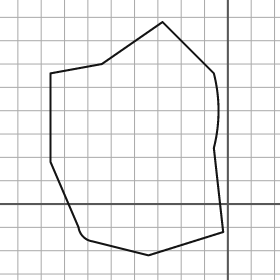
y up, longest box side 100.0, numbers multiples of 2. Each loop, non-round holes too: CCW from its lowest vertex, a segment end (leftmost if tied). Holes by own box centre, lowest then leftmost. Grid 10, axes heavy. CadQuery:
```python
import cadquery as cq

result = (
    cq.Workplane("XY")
    .moveTo(-34.0, -22.0)
    .lineTo(-2.0, -12.0)
    .lineTo(-6.0, 24.0)
    .threePointArc((-4.0, 40.0), (-6.0, 56.0))
    .lineTo(-28.0, 78.0)
    .lineTo(-54.0, 60.0)
    .lineTo(-76.0, 56.0)
    .lineTo(-76.0, 18.0)
    .lineTo(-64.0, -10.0)
    .threePointArc((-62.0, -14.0), (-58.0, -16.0))
    .close()
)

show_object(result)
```